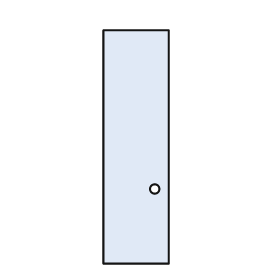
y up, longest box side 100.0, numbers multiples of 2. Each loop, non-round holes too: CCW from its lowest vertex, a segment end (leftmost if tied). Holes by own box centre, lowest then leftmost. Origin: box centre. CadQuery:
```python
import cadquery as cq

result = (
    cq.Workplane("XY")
    .moveTo(-14.0, -50.0)
    .lineTo(14.0, -50.0)
    .lineTo(14.0, 50.0)
    .lineTo(-14.0, 50.0)
    .close()
    .moveTo(8.0, -18.0)
    .circle(2.0)
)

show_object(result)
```